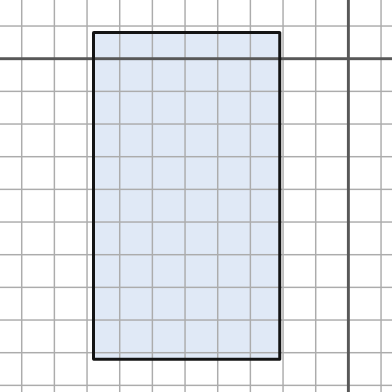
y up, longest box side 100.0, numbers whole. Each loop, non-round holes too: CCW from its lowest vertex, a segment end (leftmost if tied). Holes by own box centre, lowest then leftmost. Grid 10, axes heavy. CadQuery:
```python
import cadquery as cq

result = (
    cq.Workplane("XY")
    .moveTo(-78.0, -92.0)
    .lineTo(-21.0, -92.0)
    .lineTo(-21.0, 8.0)
    .lineTo(-78.0, 8.0)
    .close()
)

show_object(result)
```